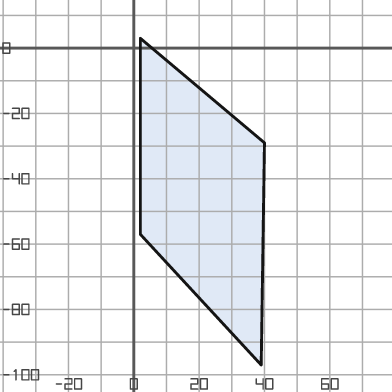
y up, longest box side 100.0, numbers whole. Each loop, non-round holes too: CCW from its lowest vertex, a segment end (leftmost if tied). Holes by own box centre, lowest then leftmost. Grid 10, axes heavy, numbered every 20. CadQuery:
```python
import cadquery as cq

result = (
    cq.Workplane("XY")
    .moveTo(39.0, -97.0)
    .lineTo(40.0, -29.0)
    .lineTo(2.0, 3.0)
    .lineTo(2.0, -57.0)
    .close()
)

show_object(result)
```